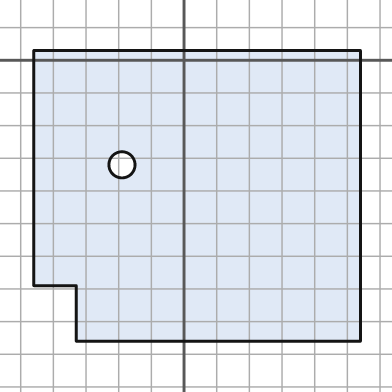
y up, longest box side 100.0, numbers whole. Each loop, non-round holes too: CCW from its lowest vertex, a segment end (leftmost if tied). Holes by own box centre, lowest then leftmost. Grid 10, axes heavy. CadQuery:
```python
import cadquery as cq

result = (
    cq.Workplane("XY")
    .moveTo(-33.0, -86.0)
    .lineTo(54.0, -86.0)
    .lineTo(54.0, 3.0)
    .lineTo(-46.0, 3.0)
    .lineTo(-46.0, -69.0)
    .lineTo(-33.0, -69.0)
    .close()
    .moveTo(-19.0, -32.0)
    .circle(4.0)
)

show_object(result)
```